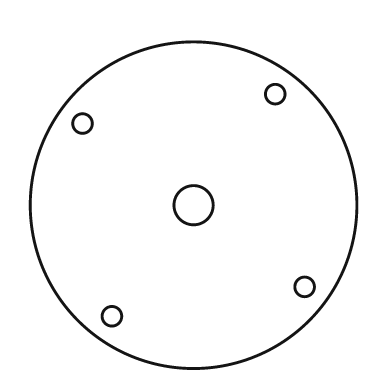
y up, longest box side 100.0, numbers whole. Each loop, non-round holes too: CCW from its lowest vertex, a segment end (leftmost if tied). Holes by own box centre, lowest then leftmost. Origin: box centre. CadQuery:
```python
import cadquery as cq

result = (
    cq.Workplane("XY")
    .moveTo(0.0, 0.0)
    .circle(50.0)
    .moveTo(-25.0, -34.0)
    .circle(3.0)
    .moveTo(34.0, -25.0)
    .circle(3.0)
    .moveTo(0.0, 0.0)
    .circle(6.0)
    .moveTo(-34.0, 25.0)
    .circle(3.0)
    .moveTo(25.0, 34.0)
    .circle(3.0)
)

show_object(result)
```